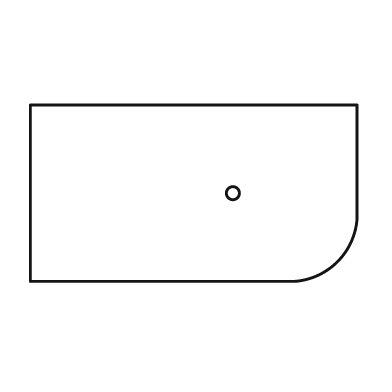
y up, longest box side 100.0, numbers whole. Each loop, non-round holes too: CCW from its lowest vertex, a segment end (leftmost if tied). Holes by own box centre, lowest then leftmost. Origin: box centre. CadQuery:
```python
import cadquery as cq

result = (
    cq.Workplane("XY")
    .moveTo(-50.0, -27.0)
    .lineTo(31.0, -27.0)
    .threePointArc((44.0, -21.0), (50.0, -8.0))
    .lineTo(50.0, 27.0)
    .lineTo(-50.0, 27.0)
    .close()
    .moveTo(12.0, 0.0)
    .circle(2.0)
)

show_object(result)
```